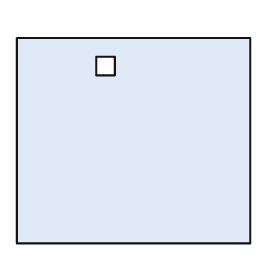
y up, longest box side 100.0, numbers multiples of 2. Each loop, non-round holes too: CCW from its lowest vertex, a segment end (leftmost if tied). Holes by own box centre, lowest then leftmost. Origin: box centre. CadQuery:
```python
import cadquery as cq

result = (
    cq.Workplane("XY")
    .moveTo(-50.0, -44.0)
    .lineTo(50.0, -44.0)
    .lineTo(50.0, 44.0)
    .lineTo(-50.0, 44.0)
    .close()
    .moveTo(-16.0, 28.0)
    .lineTo(-8.0, 28.0)
    .lineTo(-8.0, 36.0)
    .lineTo(-16.0, 36.0)
    .close()
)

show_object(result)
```